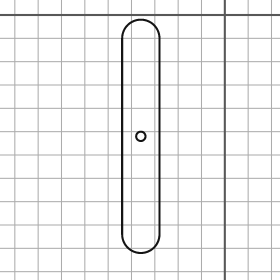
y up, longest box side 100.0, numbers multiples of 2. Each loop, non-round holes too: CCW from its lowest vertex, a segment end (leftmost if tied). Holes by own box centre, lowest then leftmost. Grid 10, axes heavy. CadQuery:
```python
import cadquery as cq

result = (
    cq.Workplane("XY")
    .moveTo(-44.0, -94.0)
    .threePointArc((-36.0, -102.0), (-28.0, -94.0))
    .lineTo(-28.0, -10.0)
    .threePointArc((-36.0, -2.0), (-44.0, -10.0))
    .close()
    .moveTo(-36.0, -52.0)
    .circle(2.0)
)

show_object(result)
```